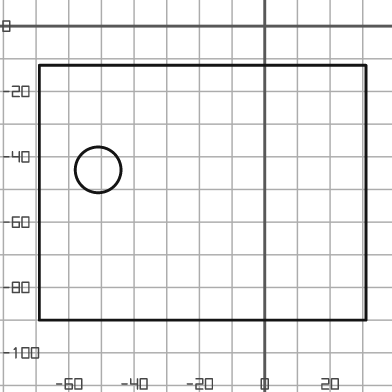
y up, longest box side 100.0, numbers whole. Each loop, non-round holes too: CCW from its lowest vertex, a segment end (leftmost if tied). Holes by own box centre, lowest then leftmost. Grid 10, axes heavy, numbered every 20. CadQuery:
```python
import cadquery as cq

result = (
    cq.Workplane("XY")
    .moveTo(-69.0, -90.0)
    .lineTo(31.0, -90.0)
    .lineTo(31.0, -12.0)
    .lineTo(-69.0, -12.0)
    .close()
    .moveTo(-51.0, -44.0)
    .circle(7.0)
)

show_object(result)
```